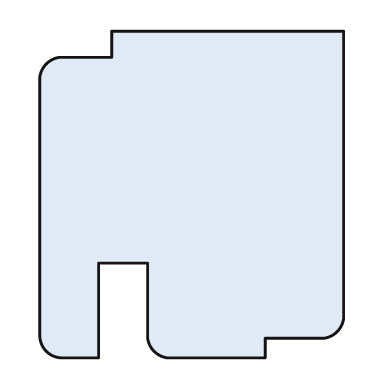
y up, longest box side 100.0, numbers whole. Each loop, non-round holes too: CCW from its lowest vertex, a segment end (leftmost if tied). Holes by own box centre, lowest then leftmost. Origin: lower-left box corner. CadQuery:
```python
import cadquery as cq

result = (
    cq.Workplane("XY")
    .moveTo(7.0, 0.0)
    .lineTo(18.0, 0.0)
    .lineTo(18.0, 29.0)
    .lineTo(33.0, 29.0)
    .lineTo(33.0, 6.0)
    .threePointArc((35.0, 2.0), (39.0, 0.0))
    .lineTo(69.0, 0.0)
    .lineTo(69.0, 6.0)
    .lineTo(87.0, 6.0)
    .threePointArc((91.0, 8.0), (93.0, 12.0))
    .lineTo(93.0, 100.0)
    .lineTo(22.0, 100.0)
    .lineTo(22.0, 92.0)
    .lineTo(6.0, 92.0)
    .threePointArc((2.0, 90.0), (0.0, 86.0))
    .lineTo(0.0, 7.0)
    .threePointArc((2.0, 2.0), (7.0, 0.0))
    .close()
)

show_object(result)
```